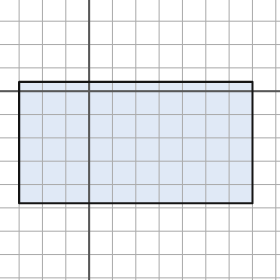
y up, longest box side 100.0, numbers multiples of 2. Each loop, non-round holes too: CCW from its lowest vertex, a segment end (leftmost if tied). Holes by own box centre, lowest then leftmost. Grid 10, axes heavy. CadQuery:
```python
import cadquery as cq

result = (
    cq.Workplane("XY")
    .moveTo(-30.0, -48.0)
    .lineTo(70.0, -48.0)
    .lineTo(70.0, 4.0)
    .lineTo(-30.0, 4.0)
    .close()
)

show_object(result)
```